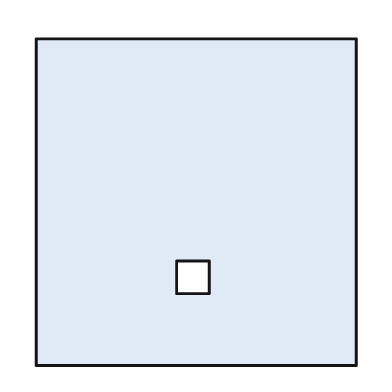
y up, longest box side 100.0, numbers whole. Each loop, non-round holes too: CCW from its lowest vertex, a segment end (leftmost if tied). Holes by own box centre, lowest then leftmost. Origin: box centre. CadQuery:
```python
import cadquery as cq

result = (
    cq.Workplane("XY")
    .moveTo(-49.0, -50.0)
    .lineTo(49.0, -50.0)
    .lineTo(49.0, 50.0)
    .lineTo(-49.0, 50.0)
    .close()
    .moveTo(-6.0, -28.0)
    .lineTo(4.0, -28.0)
    .lineTo(4.0, -18.0)
    .lineTo(-6.0, -18.0)
    .close()
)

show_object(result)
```